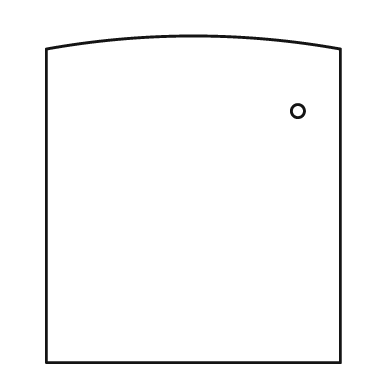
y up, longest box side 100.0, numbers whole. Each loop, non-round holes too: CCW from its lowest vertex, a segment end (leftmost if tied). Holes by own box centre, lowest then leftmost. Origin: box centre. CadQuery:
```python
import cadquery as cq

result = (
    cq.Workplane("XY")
    .moveTo(-45.0, -50.0)
    .lineTo(45.0, -50.0)
    .lineTo(45.0, 46.0)
    .threePointArc((0.0, 50.0), (-45.0, 46.0))
    .close()
    .moveTo(32.0, 27.0)
    .circle(2.0)
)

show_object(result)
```